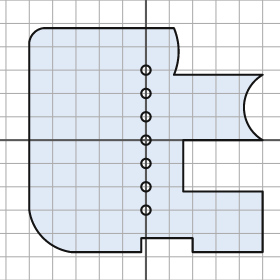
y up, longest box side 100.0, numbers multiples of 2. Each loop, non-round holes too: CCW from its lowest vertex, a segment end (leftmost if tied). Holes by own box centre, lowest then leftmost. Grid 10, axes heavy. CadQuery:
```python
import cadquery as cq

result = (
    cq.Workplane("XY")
    .moveTo(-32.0, -48.0)
    .lineTo(-2.0, -48.0)
    .lineTo(-2.0, -42.0)
    .lineTo(20.0, -42.0)
    .lineTo(20.0, -48.0)
    .lineTo(50.0, -48.0)
    .lineTo(50.0, -22.0)
    .lineTo(16.0, -22.0)
    .lineTo(16.0, 0.0)
    .lineTo(50.0, 0.0)
    .threePointArc((42.0, 14.0), (50.0, 28.0))
    .lineTo(12.0, 28.0)
    .threePointArc((14.0, 38.0), (12.0, 48.0))
    .lineTo(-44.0, 48.0)
    .threePointArc((-48.0, 46.0), (-50.0, 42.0))
    .lineTo(-50.0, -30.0)
    .threePointArc((-44.0, -42.0), (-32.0, -48.0))
    .close()
    .moveTo(0.0, -30.0)
    .circle(2.0)
    .moveTo(0.0, -20.0)
    .circle(2.0)
    .moveTo(0.0, -10.0)
    .circle(2.0)
    .moveTo(0.0, 0.0)
    .circle(2.0)
    .moveTo(0.0, 10.0)
    .circle(2.0)
    .moveTo(0.0, 20.0)
    .circle(2.0)
    .moveTo(0.0, 30.0)
    .circle(2.0)
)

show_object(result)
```